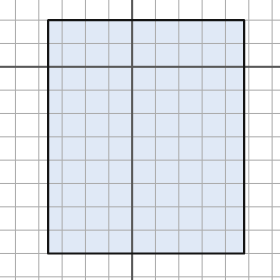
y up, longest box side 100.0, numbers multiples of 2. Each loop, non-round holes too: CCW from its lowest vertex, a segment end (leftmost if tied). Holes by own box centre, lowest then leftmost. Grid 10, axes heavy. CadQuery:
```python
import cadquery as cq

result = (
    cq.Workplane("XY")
    .moveTo(-36.0, -80.0)
    .lineTo(48.0, -80.0)
    .lineTo(48.0, 20.0)
    .lineTo(-36.0, 20.0)
    .close()
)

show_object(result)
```